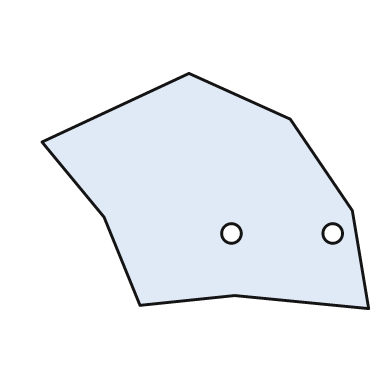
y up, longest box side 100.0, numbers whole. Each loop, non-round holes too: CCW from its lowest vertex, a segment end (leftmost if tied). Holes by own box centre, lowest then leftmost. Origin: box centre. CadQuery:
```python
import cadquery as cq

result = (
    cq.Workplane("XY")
    .moveTo(50.0, -36.0)
    .lineTo(45.0, -6.0)
    .lineTo(26.0, 22.0)
    .lineTo(-5.0, 36.0)
    .lineTo(-50.0, 15.0)
    .lineTo(-31.0, -8.0)
    .lineTo(-20.0, -35.0)
    .lineTo(9.0, -32.0)
    .close()
    .moveTo(8.0, -13.0)
    .circle(3.0)
    .moveTo(39.0, -13.0)
    .circle(3.0)
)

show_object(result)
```